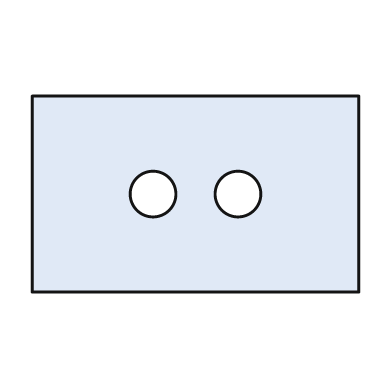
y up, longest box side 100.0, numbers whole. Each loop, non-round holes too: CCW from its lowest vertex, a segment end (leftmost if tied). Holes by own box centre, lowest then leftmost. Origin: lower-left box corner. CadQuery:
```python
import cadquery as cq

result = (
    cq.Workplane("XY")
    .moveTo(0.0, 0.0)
    .lineTo(100.0, 0.0)
    .lineTo(100.0, 60.0)
    .lineTo(0.0, 60.0)
    .close()
    .moveTo(37.0, 30.0)
    .circle(7.0)
    .moveTo(63.0, 30.0)
    .circle(7.0)
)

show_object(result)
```